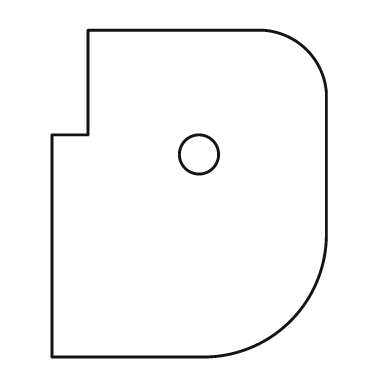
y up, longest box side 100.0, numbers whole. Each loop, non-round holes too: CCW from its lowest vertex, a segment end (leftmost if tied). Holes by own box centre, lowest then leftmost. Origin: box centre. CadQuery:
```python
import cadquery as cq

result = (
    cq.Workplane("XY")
    .moveTo(-42.0, -50.0)
    .lineTo(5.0, -50.0)
    .threePointArc((31.0, -39.0), (42.0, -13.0))
    .lineTo(42.0, 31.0)
    .threePointArc((36.0, 44.0), (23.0, 50.0))
    .lineTo(-31.0, 50.0)
    .lineTo(-31.0, 18.0)
    .lineTo(-42.0, 18.0)
    .close()
    .moveTo(3.0, 12.0)
    .circle(6.0)
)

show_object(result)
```